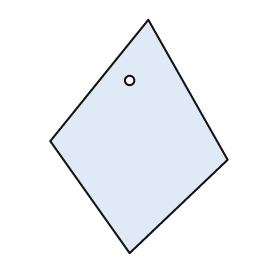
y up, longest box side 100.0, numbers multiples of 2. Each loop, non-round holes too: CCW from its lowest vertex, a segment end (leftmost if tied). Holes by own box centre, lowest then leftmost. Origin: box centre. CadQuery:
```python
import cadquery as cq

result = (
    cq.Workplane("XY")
    .moveTo(-4.0, -50.0)
    .lineTo(38.0, -10.0)
    .lineTo(4.0, 50.0)
    .lineTo(-38.0, -2.0)
    .close()
    .moveTo(-4.0, 24.0)
    .circle(2.0)
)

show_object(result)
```